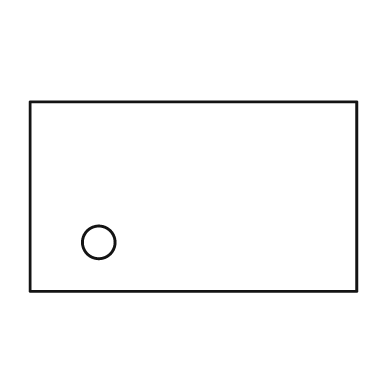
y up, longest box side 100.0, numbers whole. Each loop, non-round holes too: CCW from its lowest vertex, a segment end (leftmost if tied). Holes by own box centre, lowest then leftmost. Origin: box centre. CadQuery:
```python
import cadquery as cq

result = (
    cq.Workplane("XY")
    .moveTo(-50.0, -29.0)
    .lineTo(50.0, -29.0)
    .lineTo(50.0, 29.0)
    .lineTo(-50.0, 29.0)
    .close()
    .moveTo(-29.0, -14.0)
    .circle(5.0)
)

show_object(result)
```